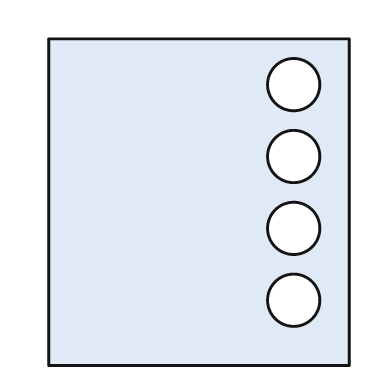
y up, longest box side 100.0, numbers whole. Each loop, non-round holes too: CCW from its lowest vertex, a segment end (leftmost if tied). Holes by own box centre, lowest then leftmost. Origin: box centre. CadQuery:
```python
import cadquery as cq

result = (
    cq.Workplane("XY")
    .moveTo(-46.0, -50.0)
    .lineTo(46.0, -50.0)
    .lineTo(46.0, 50.0)
    .lineTo(-46.0, 50.0)
    .close()
    .moveTo(29.0, -30.0)
    .circle(8.0)
    .moveTo(29.0, -8.0)
    .circle(8.0)
    .moveTo(29.0, 14.0)
    .circle(8.0)
    .moveTo(29.0, 36.0)
    .circle(8.0)
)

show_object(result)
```